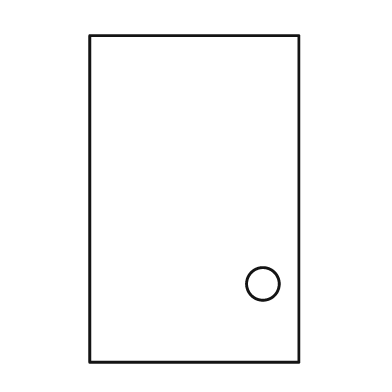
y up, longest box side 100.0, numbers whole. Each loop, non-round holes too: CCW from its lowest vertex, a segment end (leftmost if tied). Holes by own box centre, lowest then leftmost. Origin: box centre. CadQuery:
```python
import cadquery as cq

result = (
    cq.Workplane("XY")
    .moveTo(-32.0, -50.0)
    .lineTo(32.0, -50.0)
    .lineTo(32.0, 50.0)
    .lineTo(-32.0, 50.0)
    .close()
    .moveTo(21.0, -26.0)
    .circle(5.0)
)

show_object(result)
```